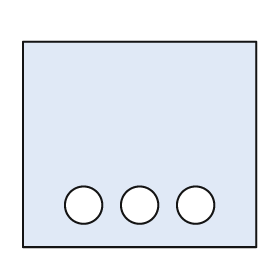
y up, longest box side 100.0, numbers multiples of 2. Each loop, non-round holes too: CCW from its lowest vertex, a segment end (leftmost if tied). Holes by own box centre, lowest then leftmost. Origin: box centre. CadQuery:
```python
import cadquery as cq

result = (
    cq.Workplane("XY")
    .moveTo(-50.0, -44.0)
    .lineTo(50.0, -44.0)
    .lineTo(50.0, 44.0)
    .lineTo(-50.0, 44.0)
    .close()
    .moveTo(-24.0, -26.0)
    .circle(8.0)
    .moveTo(0.0, -26.0)
    .circle(8.0)
    .moveTo(24.0, -26.0)
    .circle(8.0)
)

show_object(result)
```